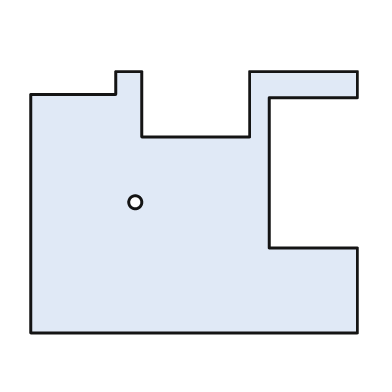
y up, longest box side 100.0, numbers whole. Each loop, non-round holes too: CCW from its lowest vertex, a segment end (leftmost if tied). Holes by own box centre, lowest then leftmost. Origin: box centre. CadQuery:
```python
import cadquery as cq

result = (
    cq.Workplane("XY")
    .moveTo(-50.0, -40.0)
    .lineTo(50.0, -40.0)
    .lineTo(50.0, -14.0)
    .lineTo(23.0, -14.0)
    .lineTo(23.0, 32.0)
    .lineTo(50.0, 32.0)
    .lineTo(50.0, 40.0)
    .lineTo(17.0, 40.0)
    .lineTo(17.0, 20.0)
    .lineTo(-16.0, 20.0)
    .lineTo(-16.0, 40.0)
    .lineTo(-24.0, 40.0)
    .lineTo(-24.0, 33.0)
    .lineTo(-50.0, 33.0)
    .close()
    .moveTo(-18.0, 0.0)
    .circle(2.0)
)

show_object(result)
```